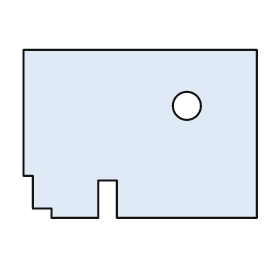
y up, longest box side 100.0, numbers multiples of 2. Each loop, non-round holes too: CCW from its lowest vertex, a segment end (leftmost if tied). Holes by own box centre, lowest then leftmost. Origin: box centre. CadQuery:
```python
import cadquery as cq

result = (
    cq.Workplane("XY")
    .moveTo(-38.0, -36.0)
    .lineTo(-18.0, -36.0)
    .lineTo(-18.0, -20.0)
    .lineTo(-10.0, -20.0)
    .lineTo(-10.0, -36.0)
    .lineTo(50.0, -36.0)
    .lineTo(50.0, 36.0)
    .lineTo(-50.0, 36.0)
    .lineTo(-50.0, -18.0)
    .lineTo(-46.0, -18.0)
    .lineTo(-46.0, -32.0)
    .lineTo(-38.0, -32.0)
    .close()
    .moveTo(20.0, 12.0)
    .circle(6.0)
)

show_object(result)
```